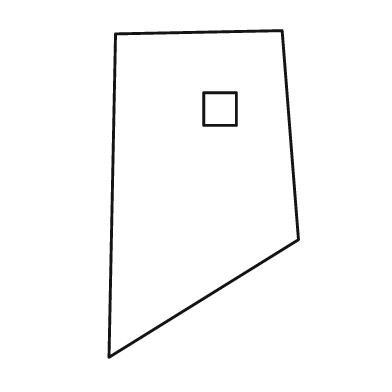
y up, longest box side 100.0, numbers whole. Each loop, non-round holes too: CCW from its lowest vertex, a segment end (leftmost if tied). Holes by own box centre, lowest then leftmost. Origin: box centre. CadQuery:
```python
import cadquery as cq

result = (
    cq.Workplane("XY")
    .moveTo(-29.0, -50.0)
    .lineTo(29.0, -14.0)
    .lineTo(24.0, 50.0)
    .lineTo(-27.0, 49.0)
    .close()
    .moveTo(0.0, 21.0)
    .lineTo(10.0, 21.0)
    .lineTo(10.0, 31.0)
    .lineTo(0.0, 31.0)
    .close()
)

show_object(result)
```